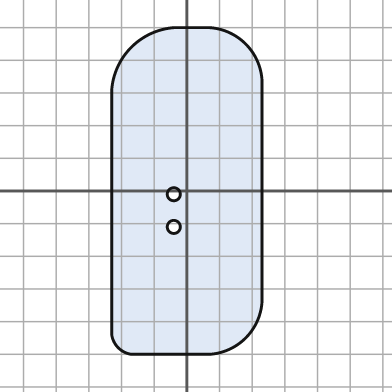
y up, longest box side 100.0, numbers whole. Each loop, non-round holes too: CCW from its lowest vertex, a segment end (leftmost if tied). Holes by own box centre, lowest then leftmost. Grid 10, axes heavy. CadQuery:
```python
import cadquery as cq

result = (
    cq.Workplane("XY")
    .moveTo(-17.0, -50.0)
    .lineTo(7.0, -50.0)
    .threePointArc((18.0, -45.0), (23.0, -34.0))
    .lineTo(23.0, 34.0)
    .threePointArc((18.0, 45.0), (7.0, 50.0))
    .lineTo(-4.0, 50.0)
    .threePointArc((-17.0, 44.0), (-23.0, 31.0))
    .lineTo(-23.0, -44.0)
    .threePointArc((-21.0, -48.0), (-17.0, -50.0))
    .close()
    .moveTo(-4.0, -11.0)
    .circle(2.0)
    .moveTo(-4.0, -1.0)
    .circle(2.0)
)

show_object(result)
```